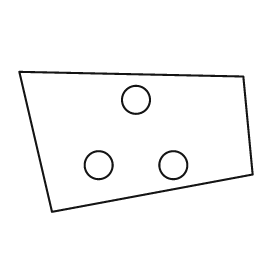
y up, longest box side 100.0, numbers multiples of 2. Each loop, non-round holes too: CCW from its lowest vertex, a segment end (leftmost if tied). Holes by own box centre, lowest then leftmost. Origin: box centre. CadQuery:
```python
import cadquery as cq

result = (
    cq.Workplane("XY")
    .moveTo(-36.0, -30.0)
    .lineTo(50.0, -14.0)
    .lineTo(46.0, 28.0)
    .lineTo(-50.0, 30.0)
    .close()
    .moveTo(-16.0, -10.0)
    .circle(6.0)
    .moveTo(16.0, -10.0)
    .circle(6.0)
    .moveTo(0.0, 18.0)
    .circle(6.0)
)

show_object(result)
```